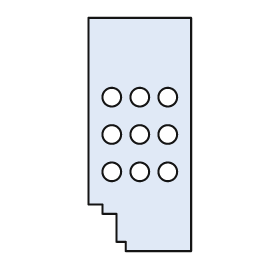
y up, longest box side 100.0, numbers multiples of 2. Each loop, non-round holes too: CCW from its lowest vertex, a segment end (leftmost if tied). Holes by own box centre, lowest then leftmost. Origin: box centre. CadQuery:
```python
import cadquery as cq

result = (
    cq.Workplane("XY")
    .moveTo(-6.0, -50.0)
    .lineTo(22.0, -50.0)
    .lineTo(22.0, 50.0)
    .lineTo(-22.0, 50.0)
    .lineTo(-22.0, -30.0)
    .lineTo(-16.0, -30.0)
    .lineTo(-16.0, -34.0)
    .lineTo(-10.0, -34.0)
    .lineTo(-10.0, -46.0)
    .lineTo(-6.0, -46.0)
    .close()
    .moveTo(-12.0, -16.0)
    .circle(4.0)
    .moveTo(0.0, -16.0)
    .circle(4.0)
    .moveTo(12.0, -16.0)
    .circle(4.0)
    .moveTo(-12.0, 0.0)
    .circle(4.0)
    .moveTo(0.0, 0.0)
    .circle(4.0)
    .moveTo(12.0, 0.0)
    .circle(4.0)
    .moveTo(-12.0, 16.0)
    .circle(4.0)
    .moveTo(0.0, 16.0)
    .circle(4.0)
    .moveTo(12.0, 16.0)
    .circle(4.0)
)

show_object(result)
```